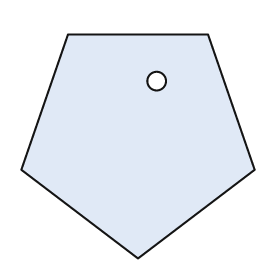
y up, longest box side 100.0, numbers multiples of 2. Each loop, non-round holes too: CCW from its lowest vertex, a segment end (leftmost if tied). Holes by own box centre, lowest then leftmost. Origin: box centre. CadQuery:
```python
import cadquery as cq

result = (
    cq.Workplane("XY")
    .moveTo(0.0, -48.0)
    .lineTo(50.0, -10.0)
    .lineTo(30.0, 48.0)
    .lineTo(-30.0, 48.0)
    .lineTo(-50.0, -10.0)
    .close()
    .moveTo(8.0, 28.0)
    .circle(4.0)
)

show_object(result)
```